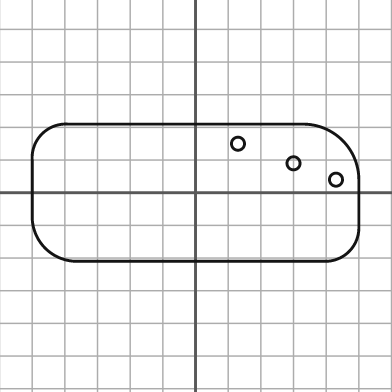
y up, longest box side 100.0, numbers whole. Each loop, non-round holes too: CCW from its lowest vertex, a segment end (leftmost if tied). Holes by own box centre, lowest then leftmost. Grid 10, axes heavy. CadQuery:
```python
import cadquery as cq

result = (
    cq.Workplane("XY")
    .moveTo(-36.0, -21.0)
    .lineTo(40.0, -21.0)
    .threePointArc((47.0, -18.0), (50.0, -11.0))
    .lineTo(50.0, 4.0)
    .threePointArc((45.0, 16.0), (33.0, 21.0))
    .lineTo(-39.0, 21.0)
    .threePointArc((-47.0, 18.0), (-50.0, 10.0))
    .lineTo(-50.0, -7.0)
    .threePointArc((-46.0, -17.0), (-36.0, -21.0))
    .close()
    .moveTo(43.0, 4.0)
    .circle(2.0)
    .moveTo(30.0, 9.0)
    .circle(2.0)
    .moveTo(13.0, 15.0)
    .circle(2.0)
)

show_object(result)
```